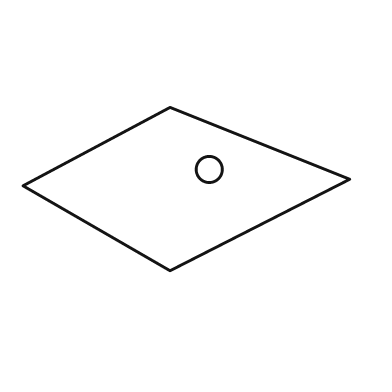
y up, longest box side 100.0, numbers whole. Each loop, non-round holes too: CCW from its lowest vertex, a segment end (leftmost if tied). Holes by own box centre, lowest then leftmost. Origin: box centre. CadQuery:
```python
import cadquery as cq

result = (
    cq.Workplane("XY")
    .moveTo(-5.0, -25.0)
    .lineTo(50.0, 3.0)
    .lineTo(-5.0, 25.0)
    .lineTo(-50.0, 1.0)
    .close()
    .moveTo(7.0, 6.0)
    .circle(4.0)
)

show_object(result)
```